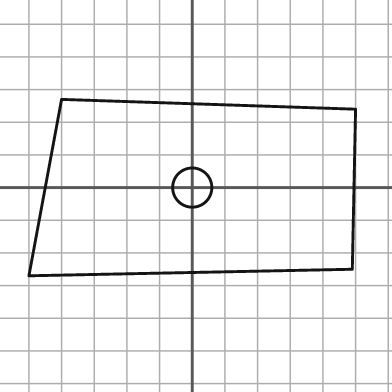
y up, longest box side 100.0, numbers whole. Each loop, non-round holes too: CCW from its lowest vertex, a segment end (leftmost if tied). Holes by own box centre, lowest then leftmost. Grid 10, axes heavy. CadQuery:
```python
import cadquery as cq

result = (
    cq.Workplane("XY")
    .moveTo(-50.0, -27.0)
    .lineTo(49.0, -25.0)
    .lineTo(50.0, 24.0)
    .lineTo(-40.0, 27.0)
    .close()
    .moveTo(0.0, 0.0)
    .circle(6.0)
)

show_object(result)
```